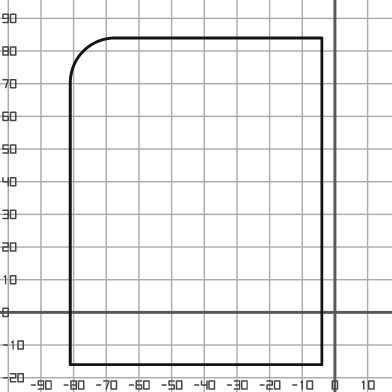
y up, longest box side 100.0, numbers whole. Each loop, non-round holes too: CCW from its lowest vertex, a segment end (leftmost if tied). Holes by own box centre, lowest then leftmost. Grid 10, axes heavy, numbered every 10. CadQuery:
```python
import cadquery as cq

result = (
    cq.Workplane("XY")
    .moveTo(-81.0, -16.0)
    .lineTo(-4.0, -16.0)
    .lineTo(-4.0, 84.0)
    .lineTo(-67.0, 84.0)
    .threePointArc((-77.0, 80.0), (-81.0, 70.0))
    .close()
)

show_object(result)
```